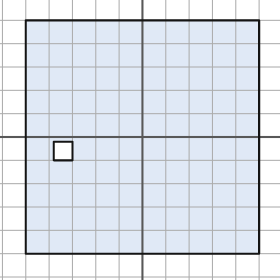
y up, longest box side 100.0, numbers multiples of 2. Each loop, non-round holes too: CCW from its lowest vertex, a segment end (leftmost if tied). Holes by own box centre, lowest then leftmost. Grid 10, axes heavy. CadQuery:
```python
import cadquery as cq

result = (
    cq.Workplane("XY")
    .moveTo(-50.0, -50.0)
    .lineTo(50.0, -50.0)
    .lineTo(50.0, 50.0)
    .lineTo(-50.0, 50.0)
    .close()
    .moveTo(-38.0, -10.0)
    .lineTo(-30.0, -10.0)
    .lineTo(-30.0, -2.0)
    .lineTo(-38.0, -2.0)
    .close()
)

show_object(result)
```